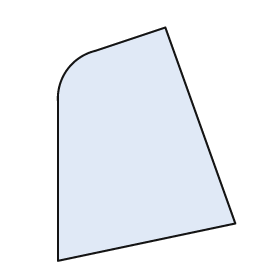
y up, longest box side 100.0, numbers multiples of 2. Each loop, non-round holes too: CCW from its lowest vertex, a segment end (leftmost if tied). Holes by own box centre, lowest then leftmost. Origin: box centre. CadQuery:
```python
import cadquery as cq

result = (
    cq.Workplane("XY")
    .moveTo(-38.0, -50.0)
    .lineTo(38.0, -34.0)
    .lineTo(8.0, 50.0)
    .lineTo(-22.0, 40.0)
    .threePointArc((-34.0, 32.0), (-38.0, 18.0))
    .close()
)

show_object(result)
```